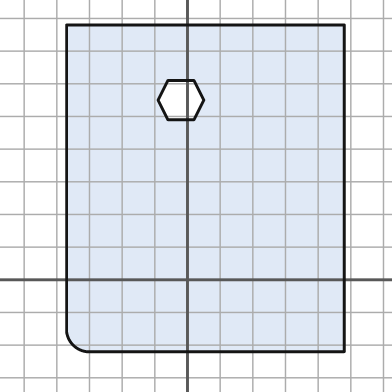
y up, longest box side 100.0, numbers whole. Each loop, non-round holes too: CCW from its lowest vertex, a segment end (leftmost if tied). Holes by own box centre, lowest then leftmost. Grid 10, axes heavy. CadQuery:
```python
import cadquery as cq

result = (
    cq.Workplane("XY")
    .moveTo(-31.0, -22.0)
    .lineTo(48.0, -22.0)
    .lineTo(48.0, 78.0)
    .lineTo(-37.0, 78.0)
    .lineTo(-37.0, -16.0)
    .threePointArc((-35.0, -20.0), (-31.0, -22.0))
    .close()
    .moveTo(-6.0, 49.0)
    .lineTo(2.0, 49.0)
    .lineTo(5.0, 55.0)
    .lineTo(2.0, 61.0)
    .lineTo(-6.0, 61.0)
    .lineTo(-9.0, 55.0)
    .close()
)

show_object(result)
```